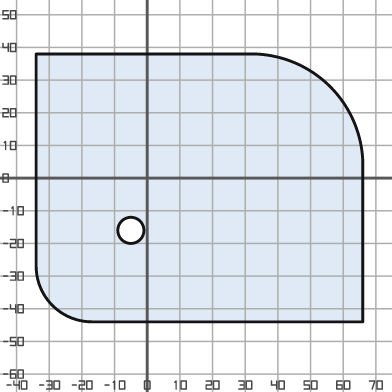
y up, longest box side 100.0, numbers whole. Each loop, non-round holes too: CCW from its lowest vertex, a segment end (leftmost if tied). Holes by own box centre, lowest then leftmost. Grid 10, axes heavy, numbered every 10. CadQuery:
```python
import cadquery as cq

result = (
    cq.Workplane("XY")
    .moveTo(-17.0, -44.0)
    .lineTo(66.0, -44.0)
    .lineTo(66.0, 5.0)
    .threePointArc((56.0, 28.0), (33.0, 38.0))
    .lineTo(-34.0, 38.0)
    .lineTo(-34.0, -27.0)
    .threePointArc((-29.0, -39.0), (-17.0, -44.0))
    .close()
    .moveTo(-5.0, -16.0)
    .circle(4.0)
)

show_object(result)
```